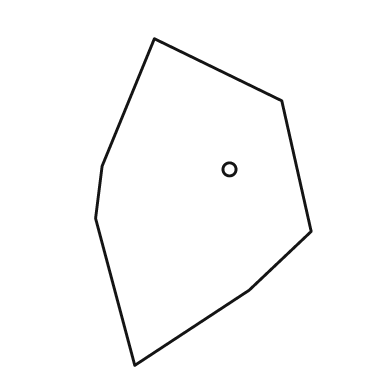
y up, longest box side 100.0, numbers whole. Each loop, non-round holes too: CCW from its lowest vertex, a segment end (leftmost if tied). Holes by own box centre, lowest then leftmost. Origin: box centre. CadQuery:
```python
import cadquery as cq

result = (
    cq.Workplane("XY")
    .moveTo(-21.0, -50.0)
    .lineTo(14.0, -27.0)
    .lineTo(33.0, -9.0)
    .lineTo(24.0, 31.0)
    .lineTo(-15.0, 50.0)
    .lineTo(-31.0, 11.0)
    .lineTo(-33.0, -5.0)
    .close()
    .moveTo(8.0, 10.0)
    .circle(2.0)
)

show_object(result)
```